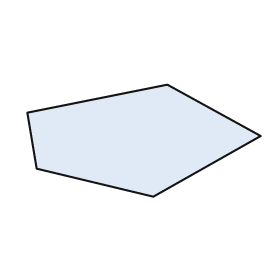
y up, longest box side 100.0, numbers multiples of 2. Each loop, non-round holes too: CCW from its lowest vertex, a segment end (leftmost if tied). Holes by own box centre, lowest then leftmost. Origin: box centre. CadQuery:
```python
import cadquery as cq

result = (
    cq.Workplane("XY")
    .moveTo(4.0, -24.0)
    .lineTo(50.0, 2.0)
    .lineTo(10.0, 24.0)
    .lineTo(-50.0, 12.0)
    .lineTo(-46.0, -12.0)
    .close()
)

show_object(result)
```